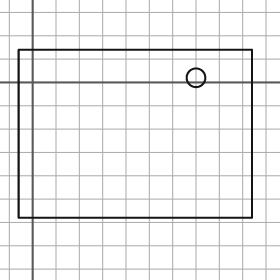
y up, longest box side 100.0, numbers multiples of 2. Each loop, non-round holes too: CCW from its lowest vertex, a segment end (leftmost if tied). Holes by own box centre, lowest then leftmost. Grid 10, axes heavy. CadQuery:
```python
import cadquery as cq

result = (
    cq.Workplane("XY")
    .moveTo(-6.0, -58.0)
    .lineTo(94.0, -58.0)
    .lineTo(94.0, 14.0)
    .lineTo(-6.0, 14.0)
    .close()
    .moveTo(70.0, 2.0)
    .circle(4.0)
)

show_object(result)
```